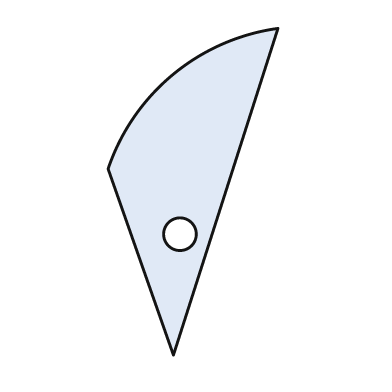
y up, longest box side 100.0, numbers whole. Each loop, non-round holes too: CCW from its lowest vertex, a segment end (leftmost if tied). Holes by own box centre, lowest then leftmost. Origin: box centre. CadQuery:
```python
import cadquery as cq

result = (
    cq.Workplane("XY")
    .moveTo(-6.0, -50.0)
    .lineTo(26.0, 50.0)
    .threePointArc((-6.0, 36.0), (-26.0, 7.0))
    .close()
    .moveTo(-4.0, -13.0)
    .circle(5.0)
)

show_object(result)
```